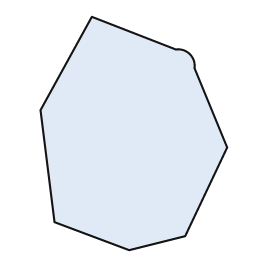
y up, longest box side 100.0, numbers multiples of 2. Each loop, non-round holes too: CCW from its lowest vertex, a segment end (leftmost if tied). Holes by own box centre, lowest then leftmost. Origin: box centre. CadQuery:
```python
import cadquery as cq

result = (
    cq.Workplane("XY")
    .moveTo(-2.0, -50.0)
    .lineTo(22.0, -44.0)
    .lineTo(40.0, -6.0)
    .lineTo(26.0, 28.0)
    .threePointArc((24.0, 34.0), (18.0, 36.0))
    .lineTo(-18.0, 50.0)
    .lineTo(-40.0, 10.0)
    .lineTo(-34.0, -38.0)
    .close()
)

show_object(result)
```